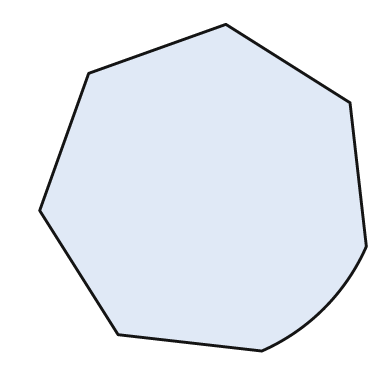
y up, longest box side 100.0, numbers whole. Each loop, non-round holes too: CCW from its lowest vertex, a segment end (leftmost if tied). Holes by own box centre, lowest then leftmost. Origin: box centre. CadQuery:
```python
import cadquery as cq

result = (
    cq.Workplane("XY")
    .moveTo(18.0, -50.0)
    .threePointArc((37.0, -37.0), (50.0, -18.0))
    .lineTo(45.0, 26.0)
    .lineTo(7.0, 50.0)
    .lineTo(-35.0, 35.0)
    .lineTo(-50.0, -7.0)
    .lineTo(-26.0, -45.0)
    .close()
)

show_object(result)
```